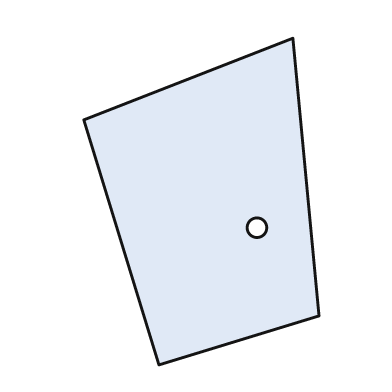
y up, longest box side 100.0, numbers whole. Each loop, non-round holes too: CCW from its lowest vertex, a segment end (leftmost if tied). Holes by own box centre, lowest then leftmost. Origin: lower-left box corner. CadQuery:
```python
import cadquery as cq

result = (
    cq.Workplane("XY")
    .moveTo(23.0, 0.0)
    .lineTo(72.0, 15.0)
    .lineTo(64.0, 100.0)
    .lineTo(0.0, 75.0)
    .close()
    .moveTo(53.0, 42.0)
    .circle(3.0)
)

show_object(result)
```